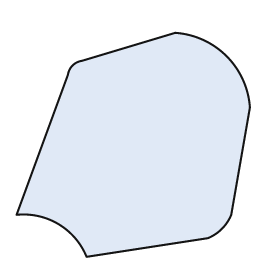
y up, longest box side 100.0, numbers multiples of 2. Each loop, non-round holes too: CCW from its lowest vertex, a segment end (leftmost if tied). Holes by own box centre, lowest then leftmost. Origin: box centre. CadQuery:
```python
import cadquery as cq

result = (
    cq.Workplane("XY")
    .moveTo(-20.0, -48.0)
    .lineTo(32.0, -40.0)
    .threePointArc((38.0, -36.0), (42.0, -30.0))
    .lineTo(50.0, 16.0)
    .threePointArc((40.0, 38.0), (18.0, 48.0))
    .lineTo(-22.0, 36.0)
    .threePointArc((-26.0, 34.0), (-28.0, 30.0))
    .lineTo(-50.0, -30.0)
    .threePointArc((-32.0, -34.0), (-20.0, -48.0))
    .close()
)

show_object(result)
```